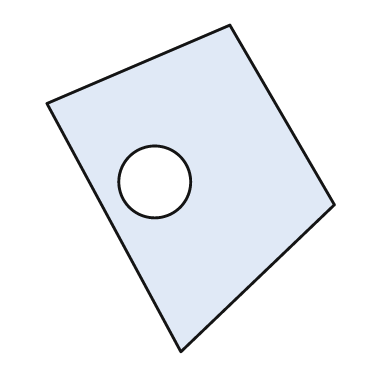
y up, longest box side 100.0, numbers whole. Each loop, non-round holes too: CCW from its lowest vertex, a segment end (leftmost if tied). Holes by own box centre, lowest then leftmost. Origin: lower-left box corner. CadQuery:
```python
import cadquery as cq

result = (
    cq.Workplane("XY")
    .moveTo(41.0, 0.0)
    .lineTo(88.0, 45.0)
    .lineTo(56.0, 100.0)
    .lineTo(0.0, 76.0)
    .close()
    .moveTo(33.0, 52.0)
    .circle(11.0)
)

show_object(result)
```